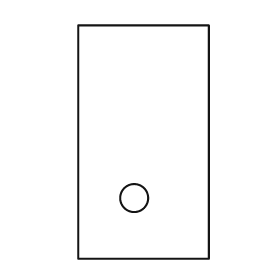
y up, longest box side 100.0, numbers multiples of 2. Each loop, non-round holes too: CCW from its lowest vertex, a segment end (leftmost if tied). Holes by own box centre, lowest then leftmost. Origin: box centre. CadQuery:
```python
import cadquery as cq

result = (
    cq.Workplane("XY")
    .moveTo(-28.0, -50.0)
    .lineTo(28.0, -50.0)
    .lineTo(28.0, 50.0)
    .lineTo(-28.0, 50.0)
    .close()
    .moveTo(-4.0, -24.0)
    .circle(6.0)
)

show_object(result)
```